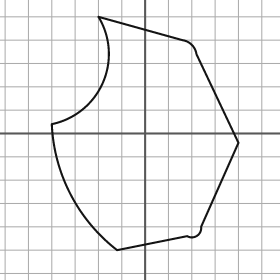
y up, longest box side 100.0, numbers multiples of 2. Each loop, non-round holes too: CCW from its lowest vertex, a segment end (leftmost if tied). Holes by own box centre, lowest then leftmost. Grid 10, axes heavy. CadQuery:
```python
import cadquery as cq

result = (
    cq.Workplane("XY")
    .moveTo(-12.0, -50.0)
    .lineTo(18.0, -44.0)
    .threePointArc((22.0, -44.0), (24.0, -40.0))
    .lineTo(40.0, -4.0)
    .lineTo(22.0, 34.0)
    .threePointArc((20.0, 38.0), (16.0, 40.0))
    .lineTo(-20.0, 50.0)
    .threePointArc((-18.0, 22.0), (-40.0, 4.0))
    .threePointArc((-32.0, -26.0), (-12.0, -50.0))
    .close()
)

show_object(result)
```